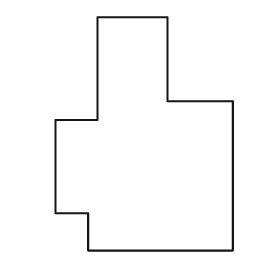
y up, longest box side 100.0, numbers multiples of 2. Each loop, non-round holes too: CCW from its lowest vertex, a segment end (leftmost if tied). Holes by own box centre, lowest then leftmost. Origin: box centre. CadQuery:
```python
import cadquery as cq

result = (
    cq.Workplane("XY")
    .moveTo(-24.0, -50.0)
    .lineTo(38.0, -50.0)
    .lineTo(38.0, 14.0)
    .lineTo(10.0, 14.0)
    .lineTo(10.0, 50.0)
    .lineTo(-20.0, 50.0)
    .lineTo(-20.0, 6.0)
    .lineTo(-38.0, 6.0)
    .lineTo(-38.0, -34.0)
    .lineTo(-24.0, -34.0)
    .close()
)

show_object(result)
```